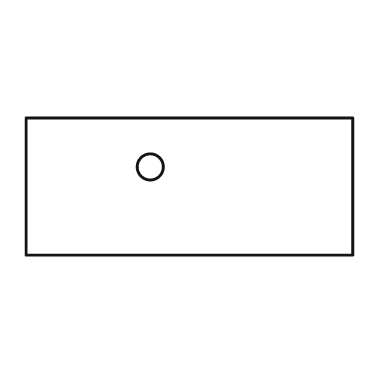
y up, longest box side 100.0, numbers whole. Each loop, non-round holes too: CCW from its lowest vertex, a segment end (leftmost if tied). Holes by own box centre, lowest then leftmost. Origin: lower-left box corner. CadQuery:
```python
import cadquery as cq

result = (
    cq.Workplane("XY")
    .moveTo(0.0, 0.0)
    .lineTo(100.0, 0.0)
    .lineTo(100.0, 42.0)
    .lineTo(0.0, 42.0)
    .close()
    .moveTo(38.0, 27.0)
    .circle(4.0)
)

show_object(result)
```